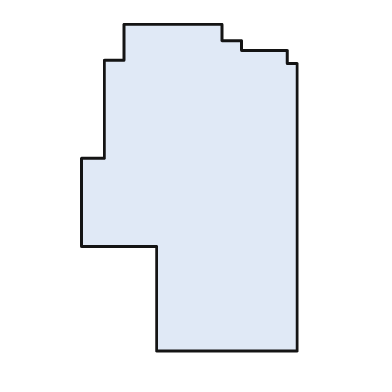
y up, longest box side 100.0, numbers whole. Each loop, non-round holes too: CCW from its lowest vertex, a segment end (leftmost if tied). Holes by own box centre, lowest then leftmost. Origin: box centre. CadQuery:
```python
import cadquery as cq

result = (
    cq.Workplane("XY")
    .moveTo(-10.0, -50.0)
    .lineTo(33.0, -50.0)
    .lineTo(33.0, 38.0)
    .lineTo(30.0, 38.0)
    .lineTo(30.0, 42.0)
    .lineTo(16.0, 42.0)
    .lineTo(16.0, 45.0)
    .lineTo(10.0, 45.0)
    .lineTo(10.0, 50.0)
    .lineTo(-20.0, 50.0)
    .lineTo(-20.0, 39.0)
    .lineTo(-26.0, 39.0)
    .lineTo(-26.0, 9.0)
    .lineTo(-33.0, 9.0)
    .lineTo(-33.0, -18.0)
    .lineTo(-10.0, -18.0)
    .close()
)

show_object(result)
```